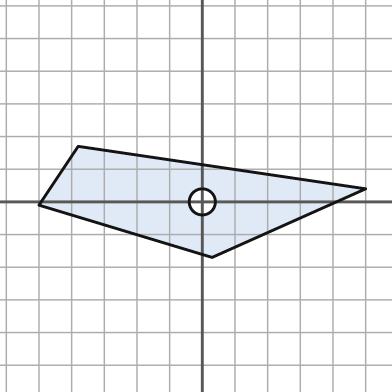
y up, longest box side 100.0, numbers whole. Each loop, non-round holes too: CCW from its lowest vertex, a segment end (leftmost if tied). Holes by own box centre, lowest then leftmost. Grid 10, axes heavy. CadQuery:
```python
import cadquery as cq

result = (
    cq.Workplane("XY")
    .moveTo(3.0, -17.0)
    .lineTo(50.0, 4.0)
    .lineTo(-38.0, 17.0)
    .lineTo(-50.0, -1.0)
    .close()
    .moveTo(0.0, 0.0)
    .circle(4.0)
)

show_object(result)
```